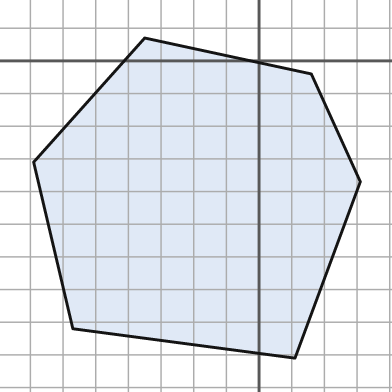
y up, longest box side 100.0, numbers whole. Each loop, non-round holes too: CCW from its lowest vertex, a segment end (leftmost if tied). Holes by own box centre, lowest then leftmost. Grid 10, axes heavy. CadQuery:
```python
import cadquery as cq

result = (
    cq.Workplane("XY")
    .moveTo(11.0, -91.0)
    .lineTo(31.0, -37.0)
    .lineTo(16.0, -4.0)
    .lineTo(-35.0, 7.0)
    .lineTo(-69.0, -31.0)
    .lineTo(-57.0, -82.0)
    .close()
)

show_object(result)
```